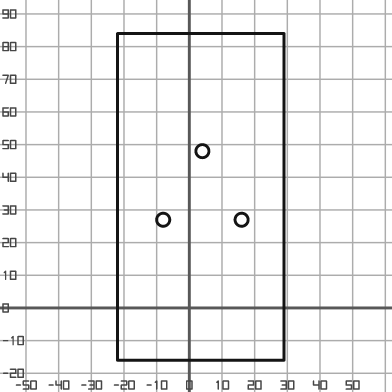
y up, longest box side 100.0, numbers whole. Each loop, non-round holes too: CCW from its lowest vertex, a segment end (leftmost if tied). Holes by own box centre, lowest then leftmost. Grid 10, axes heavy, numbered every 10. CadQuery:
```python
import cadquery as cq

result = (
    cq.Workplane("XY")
    .moveTo(-22.0, -16.0)
    .lineTo(29.0, -16.0)
    .lineTo(29.0, 84.0)
    .lineTo(-22.0, 84.0)
    .close()
    .moveTo(-8.0, 27.0)
    .circle(2.0)
    .moveTo(16.0, 27.0)
    .circle(2.0)
    .moveTo(4.0, 48.0)
    .circle(2.0)
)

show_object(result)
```